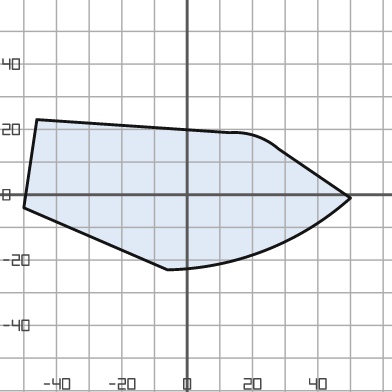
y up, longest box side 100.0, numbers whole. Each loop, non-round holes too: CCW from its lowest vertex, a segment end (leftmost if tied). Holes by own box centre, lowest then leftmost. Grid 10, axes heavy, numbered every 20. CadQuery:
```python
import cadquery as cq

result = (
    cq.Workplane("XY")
    .moveTo(-6.0, -23.0)
    .threePointArc((24.0, -17.0), (50.0, -1.0))
    .lineTo(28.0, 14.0)
    .threePointArc((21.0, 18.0), (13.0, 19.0))
    .lineTo(-46.0, 23.0)
    .lineTo(-50.0, -4.0)
    .close()
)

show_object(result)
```